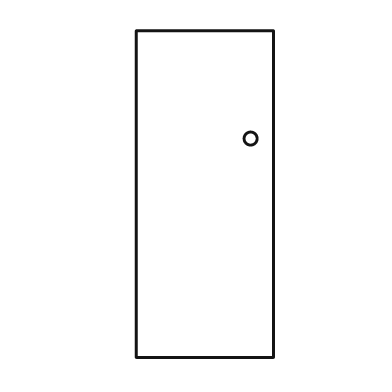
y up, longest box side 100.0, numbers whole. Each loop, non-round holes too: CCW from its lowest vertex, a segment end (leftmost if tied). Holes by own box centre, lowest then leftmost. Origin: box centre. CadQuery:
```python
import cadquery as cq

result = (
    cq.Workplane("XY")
    .moveTo(-21.0, -50.0)
    .lineTo(21.0, -50.0)
    .lineTo(21.0, 50.0)
    .lineTo(-21.0, 50.0)
    .close()
    .moveTo(14.0, 17.0)
    .circle(2.0)
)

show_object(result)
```